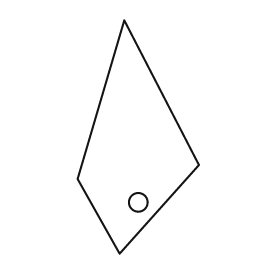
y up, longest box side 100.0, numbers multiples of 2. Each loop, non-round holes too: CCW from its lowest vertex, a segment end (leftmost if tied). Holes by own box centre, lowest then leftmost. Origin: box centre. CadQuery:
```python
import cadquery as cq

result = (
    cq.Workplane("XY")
    .moveTo(-8.0, -50.0)
    .lineTo(26.0, -12.0)
    .lineTo(-6.0, 50.0)
    .lineTo(-26.0, -18.0)
    .close()
    .moveTo(0.0, -28.0)
    .circle(4.0)
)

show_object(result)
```